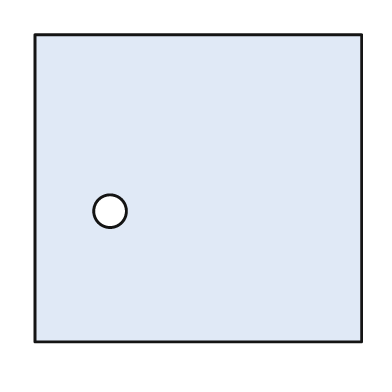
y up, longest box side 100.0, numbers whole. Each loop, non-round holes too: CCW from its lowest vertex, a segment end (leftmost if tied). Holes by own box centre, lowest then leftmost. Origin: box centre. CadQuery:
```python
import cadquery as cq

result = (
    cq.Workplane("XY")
    .moveTo(-50.0, -47.0)
    .lineTo(50.0, -47.0)
    .lineTo(50.0, 47.0)
    .lineTo(-50.0, 47.0)
    .close()
    .moveTo(-27.0, -7.0)
    .circle(5.0)
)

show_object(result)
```